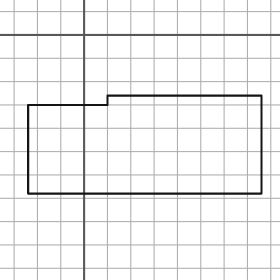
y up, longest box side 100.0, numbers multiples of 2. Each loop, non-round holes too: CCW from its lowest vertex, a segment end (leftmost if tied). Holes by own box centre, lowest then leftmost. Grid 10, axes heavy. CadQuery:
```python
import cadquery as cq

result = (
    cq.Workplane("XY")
    .moveTo(-24.0, -68.0)
    .lineTo(76.0, -68.0)
    .lineTo(76.0, -26.0)
    .lineTo(10.0, -26.0)
    .lineTo(10.0, -30.0)
    .lineTo(-24.0, -30.0)
    .close()
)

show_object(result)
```